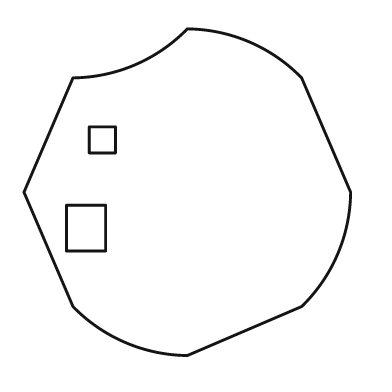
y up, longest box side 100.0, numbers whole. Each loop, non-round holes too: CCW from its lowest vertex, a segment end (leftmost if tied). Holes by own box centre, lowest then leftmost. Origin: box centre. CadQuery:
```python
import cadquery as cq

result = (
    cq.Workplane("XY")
    .moveTo(0.0, -50.0)
    .lineTo(35.0, -35.0)
    .threePointArc((46.0, -19.0), (50.0, 0.0))
    .lineTo(35.0, 35.0)
    .threePointArc((19.0, 46.0), (0.0, 50.0))
    .threePointArc((-16.0, 39.0), (-35.0, 35.0))
    .lineTo(-50.0, 0.0)
    .lineTo(-35.0, -35.0)
    .threePointArc((-19.0, -46.0), (0.0, -50.0))
    .close()
    .moveTo(-37.0, -18.0)
    .lineTo(-25.0, -18.0)
    .lineTo(-25.0, -4.0)
    .lineTo(-37.0, -4.0)
    .close()
    .moveTo(-30.0, 12.0)
    .lineTo(-22.0, 12.0)
    .lineTo(-22.0, 20.0)
    .lineTo(-30.0, 20.0)
    .close()
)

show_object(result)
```